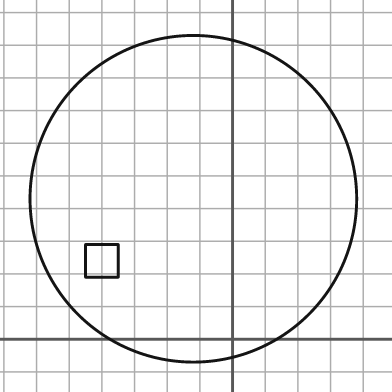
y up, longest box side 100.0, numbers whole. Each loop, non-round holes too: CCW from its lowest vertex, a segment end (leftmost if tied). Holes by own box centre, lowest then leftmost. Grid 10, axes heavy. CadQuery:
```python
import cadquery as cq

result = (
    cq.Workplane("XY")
    .moveTo(-12.0, 43.0)
    .circle(50.0)
    .moveTo(-45.0, 19.0)
    .lineTo(-35.0, 19.0)
    .lineTo(-35.0, 29.0)
    .lineTo(-45.0, 29.0)
    .close()
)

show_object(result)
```